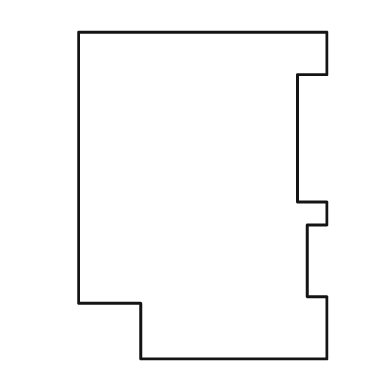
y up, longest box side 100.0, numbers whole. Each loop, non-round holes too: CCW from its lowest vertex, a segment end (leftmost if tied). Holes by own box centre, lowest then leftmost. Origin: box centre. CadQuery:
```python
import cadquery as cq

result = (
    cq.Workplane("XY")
    .moveTo(-19.0, -50.0)
    .lineTo(38.0, -50.0)
    .lineTo(38.0, -31.0)
    .lineTo(32.0, -31.0)
    .lineTo(32.0, -9.0)
    .lineTo(38.0, -9.0)
    .lineTo(38.0, -2.0)
    .lineTo(29.0, -2.0)
    .lineTo(29.0, 37.0)
    .lineTo(38.0, 37.0)
    .lineTo(38.0, 50.0)
    .lineTo(-38.0, 50.0)
    .lineTo(-38.0, -33.0)
    .lineTo(-19.0, -33.0)
    .close()
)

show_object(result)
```